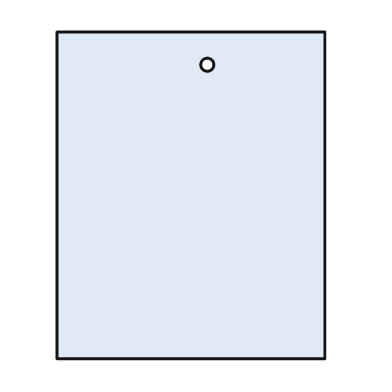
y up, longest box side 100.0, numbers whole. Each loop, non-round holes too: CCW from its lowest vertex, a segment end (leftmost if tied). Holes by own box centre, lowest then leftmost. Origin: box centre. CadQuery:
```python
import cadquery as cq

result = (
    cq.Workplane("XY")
    .moveTo(-41.0, -50.0)
    .lineTo(41.0, -50.0)
    .lineTo(41.0, 50.0)
    .lineTo(-41.0, 50.0)
    .close()
    .moveTo(5.0, 40.0)
    .circle(2.0)
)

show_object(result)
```